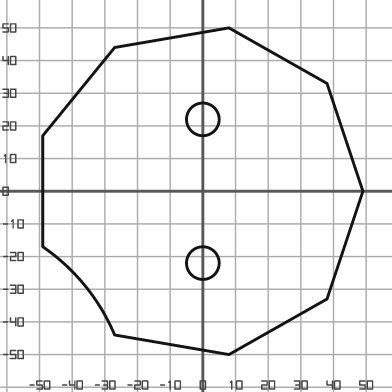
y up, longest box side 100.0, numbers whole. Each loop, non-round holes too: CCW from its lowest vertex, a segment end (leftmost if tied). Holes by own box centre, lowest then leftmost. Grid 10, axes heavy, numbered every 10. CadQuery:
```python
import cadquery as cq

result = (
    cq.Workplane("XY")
    .moveTo(8.0, -50.0)
    .lineTo(38.0, -33.0)
    .lineTo(49.0, 0.0)
    .lineTo(38.0, 33.0)
    .lineTo(8.0, 50.0)
    .lineTo(-27.0, 44.0)
    .lineTo(-49.0, 17.0)
    .lineTo(-49.0, -17.0)
    .threePointArc((-36.0, -29.0), (-27.0, -44.0))
    .close()
    .moveTo(0.0, -22.0)
    .circle(5.0)
    .moveTo(0.0, 22.0)
    .circle(5.0)
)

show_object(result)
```